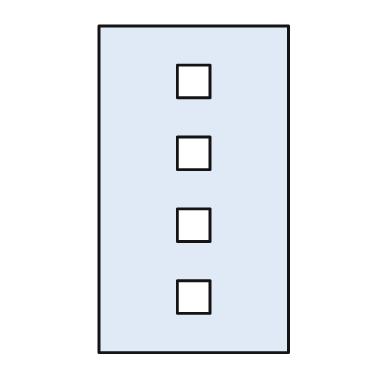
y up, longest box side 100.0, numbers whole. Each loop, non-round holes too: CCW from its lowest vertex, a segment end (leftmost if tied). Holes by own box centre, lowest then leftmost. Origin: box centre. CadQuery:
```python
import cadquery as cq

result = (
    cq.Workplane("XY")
    .moveTo(-29.0, -50.0)
    .lineTo(29.0, -50.0)
    .lineTo(29.0, 50.0)
    .lineTo(-29.0, 50.0)
    .close()
    .moveTo(-5.0, -38.0)
    .lineTo(5.0, -38.0)
    .lineTo(5.0, -28.0)
    .lineTo(-5.0, -28.0)
    .close()
    .moveTo(-5.0, -16.0)
    .lineTo(5.0, -16.0)
    .lineTo(5.0, -6.0)
    .lineTo(-5.0, -6.0)
    .close()
    .moveTo(-5.0, 6.0)
    .lineTo(5.0, 6.0)
    .lineTo(5.0, 16.0)
    .lineTo(-5.0, 16.0)
    .close()
    .moveTo(-5.0, 28.0)
    .lineTo(5.0, 28.0)
    .lineTo(5.0, 38.0)
    .lineTo(-5.0, 38.0)
    .close()
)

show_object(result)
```